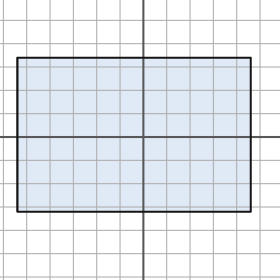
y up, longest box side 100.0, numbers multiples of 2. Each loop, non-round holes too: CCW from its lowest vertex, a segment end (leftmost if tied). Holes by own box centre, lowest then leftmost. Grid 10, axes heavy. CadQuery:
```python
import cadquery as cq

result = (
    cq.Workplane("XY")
    .moveTo(-54.0, -32.0)
    .lineTo(46.0, -32.0)
    .lineTo(46.0, 34.0)
    .lineTo(-54.0, 34.0)
    .close()
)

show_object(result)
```